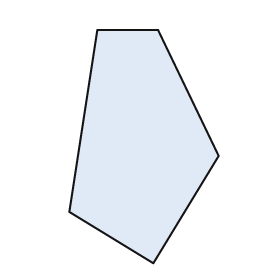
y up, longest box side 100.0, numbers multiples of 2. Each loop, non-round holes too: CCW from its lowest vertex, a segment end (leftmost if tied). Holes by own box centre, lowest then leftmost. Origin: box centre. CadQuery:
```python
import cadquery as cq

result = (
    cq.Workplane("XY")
    .moveTo(4.0, -50.0)
    .lineTo(32.0, -4.0)
    .lineTo(6.0, 50.0)
    .lineTo(-20.0, 50.0)
    .lineTo(-32.0, -28.0)
    .close()
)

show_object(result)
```